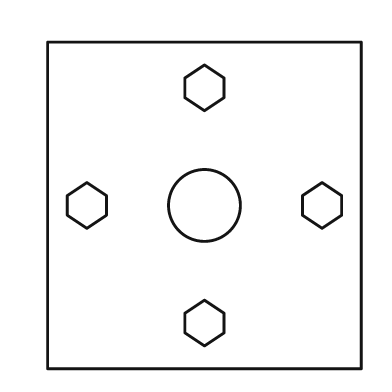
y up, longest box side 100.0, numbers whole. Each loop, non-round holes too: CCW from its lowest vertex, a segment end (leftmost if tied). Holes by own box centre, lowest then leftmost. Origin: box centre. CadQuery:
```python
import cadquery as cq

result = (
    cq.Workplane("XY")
    .moveTo(-48.0, -50.0)
    .lineTo(48.0, -50.0)
    .lineTo(48.0, 50.0)
    .lineTo(-48.0, 50.0)
    .close()
    .moveTo(0.0, -43.0)
    .lineTo(6.0, -39.0)
    .lineTo(6.0, -33.0)
    .lineTo(0.0, -29.0)
    .lineTo(-6.0, -33.0)
    .lineTo(-6.0, -39.0)
    .close()
    .moveTo(-36.0, -7.0)
    .lineTo(-30.0, -3.0)
    .lineTo(-30.0, 3.0)
    .lineTo(-36.0, 7.0)
    .lineTo(-42.0, 3.0)
    .lineTo(-42.0, -3.0)
    .close()
    .moveTo(0.0, 0.0)
    .circle(11.0)
    .moveTo(36.0, -7.0)
    .lineTo(42.0, -3.0)
    .lineTo(42.0, 3.0)
    .lineTo(36.0, 7.0)
    .lineTo(30.0, 3.0)
    .lineTo(30.0, -3.0)
    .close()
    .moveTo(0.0, 29.0)
    .lineTo(6.0, 33.0)
    .lineTo(6.0, 39.0)
    .lineTo(0.0, 43.0)
    .lineTo(-6.0, 39.0)
    .lineTo(-6.0, 33.0)
    .close()
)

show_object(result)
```